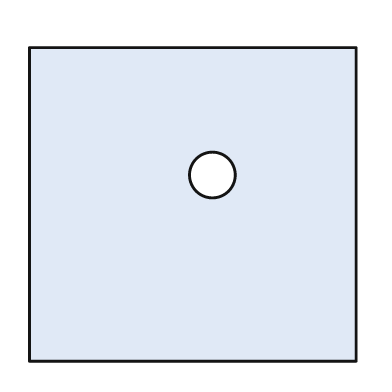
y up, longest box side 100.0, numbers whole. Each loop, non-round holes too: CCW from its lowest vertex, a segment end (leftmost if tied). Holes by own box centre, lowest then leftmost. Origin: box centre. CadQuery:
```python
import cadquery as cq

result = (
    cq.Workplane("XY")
    .moveTo(-50.0, -48.0)
    .lineTo(50.0, -48.0)
    .lineTo(50.0, 48.0)
    .lineTo(-50.0, 48.0)
    .close()
    .moveTo(6.0, 9.0)
    .circle(7.0)
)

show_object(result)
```